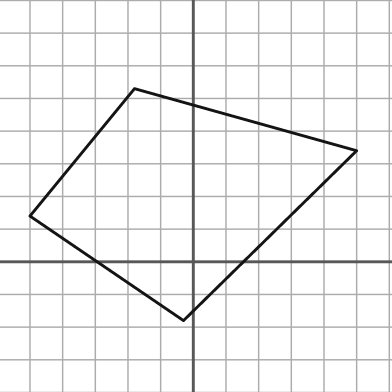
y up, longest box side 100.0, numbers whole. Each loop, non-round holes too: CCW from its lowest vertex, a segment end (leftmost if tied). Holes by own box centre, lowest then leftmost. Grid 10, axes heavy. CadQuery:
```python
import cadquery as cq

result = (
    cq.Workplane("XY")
    .moveTo(-3.0, -18.0)
    .lineTo(50.0, 34.0)
    .lineTo(-18.0, 53.0)
    .lineTo(-50.0, 14.0)
    .close()
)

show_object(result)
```